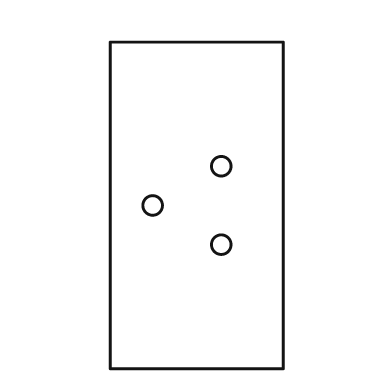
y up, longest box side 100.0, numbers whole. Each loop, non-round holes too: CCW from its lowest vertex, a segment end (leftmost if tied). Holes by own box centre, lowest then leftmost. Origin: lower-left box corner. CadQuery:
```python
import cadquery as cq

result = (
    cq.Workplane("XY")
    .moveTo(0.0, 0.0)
    .lineTo(53.0, 0.0)
    .lineTo(53.0, 100.0)
    .lineTo(0.0, 100.0)
    .close()
    .moveTo(34.0, 38.0)
    .circle(3.0)
    .moveTo(13.0, 50.0)
    .circle(3.0)
    .moveTo(34.0, 62.0)
    .circle(3.0)
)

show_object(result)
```